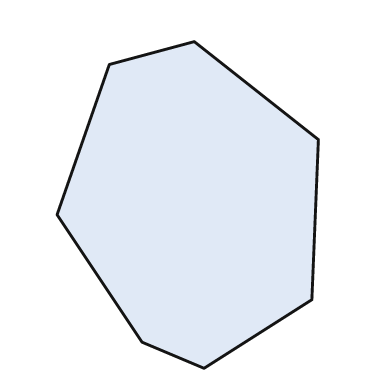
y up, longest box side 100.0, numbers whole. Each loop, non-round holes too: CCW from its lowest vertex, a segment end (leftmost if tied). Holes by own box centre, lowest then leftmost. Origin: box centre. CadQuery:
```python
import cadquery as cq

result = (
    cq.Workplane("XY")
    .moveTo(5.0, -50.0)
    .lineTo(38.0, -29.0)
    .lineTo(40.0, 20.0)
    .lineTo(2.0, 50.0)
    .lineTo(-24.0, 43.0)
    .lineTo(-40.0, -3.0)
    .lineTo(-14.0, -42.0)
    .close()
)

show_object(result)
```